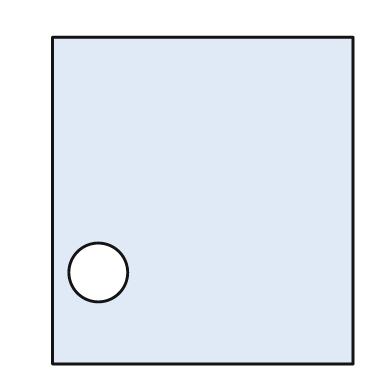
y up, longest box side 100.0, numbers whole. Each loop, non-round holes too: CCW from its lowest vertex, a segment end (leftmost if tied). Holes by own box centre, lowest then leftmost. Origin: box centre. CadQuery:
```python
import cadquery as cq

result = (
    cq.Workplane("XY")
    .moveTo(-46.0, -50.0)
    .lineTo(46.0, -50.0)
    .lineTo(46.0, 50.0)
    .lineTo(-46.0, 50.0)
    .close()
    .moveTo(-32.0, -22.0)
    .circle(9.0)
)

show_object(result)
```